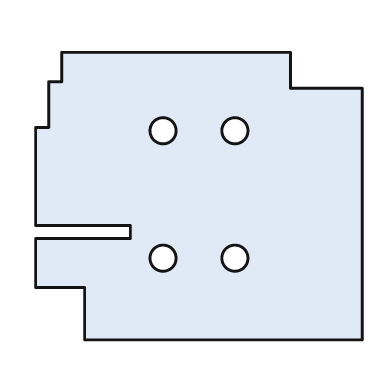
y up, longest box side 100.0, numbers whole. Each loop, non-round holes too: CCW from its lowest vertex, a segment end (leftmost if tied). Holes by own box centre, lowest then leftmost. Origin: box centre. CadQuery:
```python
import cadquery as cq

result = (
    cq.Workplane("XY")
    .moveTo(-35.0, -44.0)
    .lineTo(50.0, -44.0)
    .lineTo(50.0, 33.0)
    .lineTo(28.0, 33.0)
    .lineTo(28.0, 44.0)
    .lineTo(-42.0, 44.0)
    .lineTo(-42.0, 35.0)
    .lineTo(-46.0, 35.0)
    .lineTo(-46.0, 21.0)
    .lineTo(-50.0, 21.0)
    .lineTo(-50.0, -9.0)
    .lineTo(-21.0, -9.0)
    .lineTo(-21.0, -13.0)
    .lineTo(-50.0, -13.0)
    .lineTo(-50.0, -28.0)
    .lineTo(-35.0, -28.0)
    .close()
    .moveTo(-11.0, -19.0)
    .circle(4.0)
    .moveTo(11.0, -19.0)
    .circle(4.0)
    .moveTo(-11.0, 20.0)
    .circle(4.0)
    .moveTo(11.0, 20.0)
    .circle(4.0)
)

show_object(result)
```